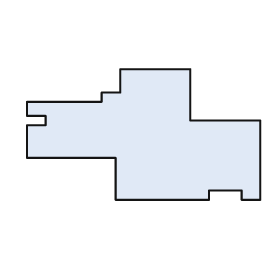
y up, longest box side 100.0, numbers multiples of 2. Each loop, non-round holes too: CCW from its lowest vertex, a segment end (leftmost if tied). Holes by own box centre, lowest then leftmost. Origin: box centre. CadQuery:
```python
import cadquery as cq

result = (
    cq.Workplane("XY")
    .moveTo(-12.0, -28.0)
    .lineTo(28.0, -28.0)
    .lineTo(28.0, -24.0)
    .lineTo(42.0, -24.0)
    .lineTo(42.0, -28.0)
    .lineTo(50.0, -28.0)
    .lineTo(50.0, 6.0)
    .lineTo(20.0, 6.0)
    .lineTo(20.0, 28.0)
    .lineTo(-10.0, 28.0)
    .lineTo(-10.0, 18.0)
    .lineTo(-18.0, 18.0)
    .lineTo(-18.0, 14.0)
    .lineTo(-50.0, 14.0)
    .lineTo(-50.0, 8.0)
    .lineTo(-42.0, 8.0)
    .lineTo(-42.0, 4.0)
    .lineTo(-50.0, 4.0)
    .lineTo(-50.0, -10.0)
    .lineTo(-12.0, -10.0)
    .close()
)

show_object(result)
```